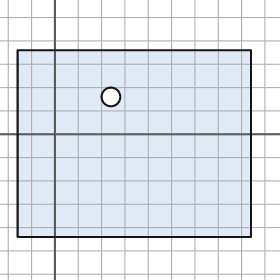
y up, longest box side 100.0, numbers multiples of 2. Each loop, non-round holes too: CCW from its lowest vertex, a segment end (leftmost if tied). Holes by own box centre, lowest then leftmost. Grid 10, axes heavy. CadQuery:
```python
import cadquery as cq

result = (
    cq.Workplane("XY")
    .moveTo(-16.0, -44.0)
    .lineTo(84.0, -44.0)
    .lineTo(84.0, 36.0)
    .lineTo(-16.0, 36.0)
    .close()
    .moveTo(24.0, 16.0)
    .circle(4.0)
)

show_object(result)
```